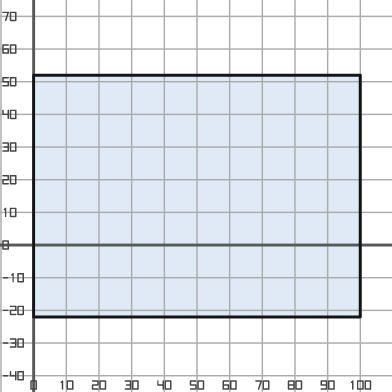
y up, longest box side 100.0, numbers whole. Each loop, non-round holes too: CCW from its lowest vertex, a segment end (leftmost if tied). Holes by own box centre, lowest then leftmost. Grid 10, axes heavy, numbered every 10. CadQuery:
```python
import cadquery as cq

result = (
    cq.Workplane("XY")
    .moveTo(0.0, -22.0)
    .lineTo(100.0, -22.0)
    .lineTo(100.0, 52.0)
    .lineTo(0.0, 52.0)
    .close()
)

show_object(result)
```